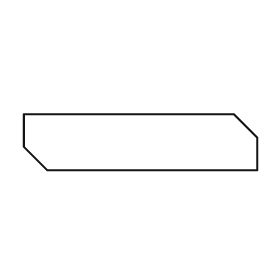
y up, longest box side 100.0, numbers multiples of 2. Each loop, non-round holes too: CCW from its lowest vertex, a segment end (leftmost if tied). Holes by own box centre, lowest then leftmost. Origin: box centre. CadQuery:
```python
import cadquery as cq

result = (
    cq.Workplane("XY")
    .moveTo(-40.0, -12.0)
    .lineTo(50.0, -12.0)
    .lineTo(50.0, 2.0)
    .lineTo(40.0, 12.0)
    .lineTo(-50.0, 12.0)
    .lineTo(-50.0, -2.0)
    .close()
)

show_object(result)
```